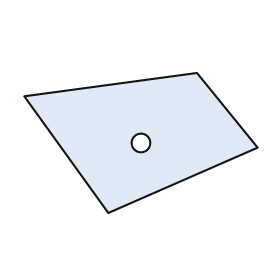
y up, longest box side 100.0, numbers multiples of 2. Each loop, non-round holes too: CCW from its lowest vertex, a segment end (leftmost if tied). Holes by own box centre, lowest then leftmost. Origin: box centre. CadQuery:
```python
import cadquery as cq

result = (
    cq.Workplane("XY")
    .moveTo(-14.0, -30.0)
    .lineTo(50.0, -2.0)
    .lineTo(24.0, 30.0)
    .lineTo(-50.0, 20.0)
    .close()
    .moveTo(0.0, 0.0)
    .circle(4.0)
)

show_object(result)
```